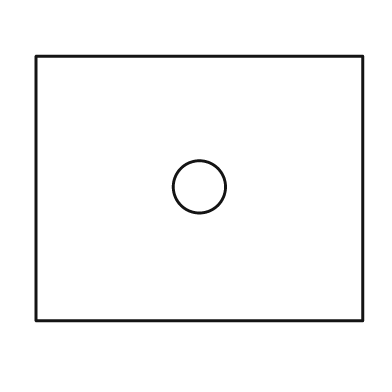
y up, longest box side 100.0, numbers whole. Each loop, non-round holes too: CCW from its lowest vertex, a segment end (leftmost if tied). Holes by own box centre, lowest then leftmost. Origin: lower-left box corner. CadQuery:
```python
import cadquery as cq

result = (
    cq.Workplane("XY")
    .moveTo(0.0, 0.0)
    .lineTo(100.0, 0.0)
    .lineTo(100.0, 81.0)
    .lineTo(0.0, 81.0)
    .close()
    .moveTo(50.0, 41.0)
    .circle(8.0)
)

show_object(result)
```